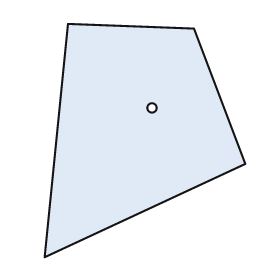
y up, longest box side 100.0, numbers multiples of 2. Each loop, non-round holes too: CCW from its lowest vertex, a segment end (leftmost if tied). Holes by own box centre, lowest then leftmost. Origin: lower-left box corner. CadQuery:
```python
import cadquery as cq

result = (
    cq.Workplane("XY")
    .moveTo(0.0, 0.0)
    .lineTo(86.0, 40.0)
    .lineTo(64.0, 98.0)
    .lineTo(10.0, 100.0)
    .close()
    .moveTo(46.0, 64.0)
    .circle(2.0)
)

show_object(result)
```